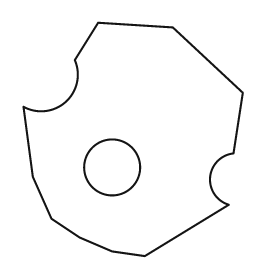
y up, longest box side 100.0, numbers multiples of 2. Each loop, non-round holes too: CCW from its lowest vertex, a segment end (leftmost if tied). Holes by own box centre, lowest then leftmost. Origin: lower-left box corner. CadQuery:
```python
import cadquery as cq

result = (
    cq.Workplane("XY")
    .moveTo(52.0, 0.0)
    .lineTo(88.0, 22.0)
    .threePointArc((80.0, 34.0), (90.0, 44.0))
    .lineTo(94.0, 70.0)
    .lineTo(64.0, 98.0)
    .lineTo(32.0, 100.0)
    .lineTo(22.0, 84.0)
    .threePointArc((18.0, 66.0), (0.0, 64.0))
    .lineTo(4.0, 34.0)
    .lineTo(12.0, 16.0)
    .lineTo(24.0, 8.0)
    .lineTo(38.0, 2.0)
    .close()
    .moveTo(38.0, 38.0)
    .circle(12.0)
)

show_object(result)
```